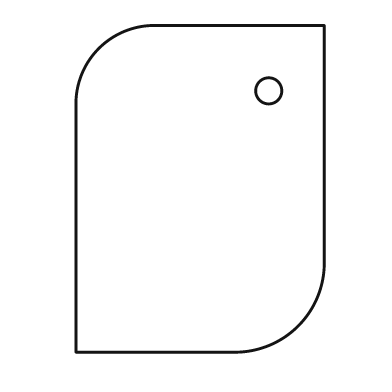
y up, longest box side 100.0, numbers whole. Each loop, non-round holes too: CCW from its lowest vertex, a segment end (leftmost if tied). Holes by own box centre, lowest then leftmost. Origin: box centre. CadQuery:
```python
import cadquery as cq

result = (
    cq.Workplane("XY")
    .moveTo(-38.0, -50.0)
    .lineTo(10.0, -50.0)
    .threePointArc((30.0, -42.0), (38.0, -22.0))
    .lineTo(38.0, 50.0)
    .lineTo(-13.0, 50.0)
    .threePointArc((-31.0, 43.0), (-38.0, 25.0))
    .close()
    .moveTo(21.0, 30.0)
    .circle(4.0)
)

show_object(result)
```